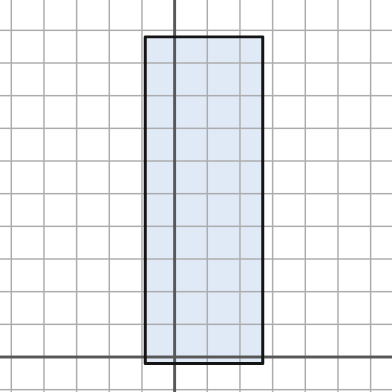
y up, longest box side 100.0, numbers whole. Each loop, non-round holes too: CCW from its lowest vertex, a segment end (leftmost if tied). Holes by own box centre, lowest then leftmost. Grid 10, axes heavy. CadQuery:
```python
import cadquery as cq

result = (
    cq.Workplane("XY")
    .moveTo(-9.0, -2.0)
    .lineTo(27.0, -2.0)
    .lineTo(27.0, 98.0)
    .lineTo(-9.0, 98.0)
    .close()
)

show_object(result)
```